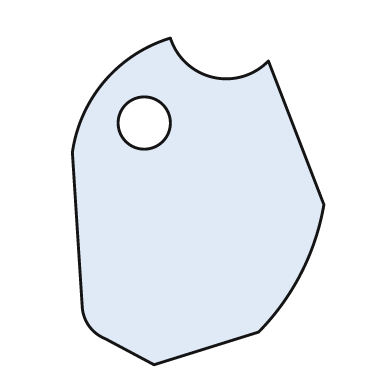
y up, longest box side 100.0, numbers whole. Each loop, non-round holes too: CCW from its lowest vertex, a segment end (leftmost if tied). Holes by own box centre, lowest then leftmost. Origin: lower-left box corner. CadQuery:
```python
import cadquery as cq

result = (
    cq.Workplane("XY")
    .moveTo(25.0, 0.0)
    .lineTo(57.0, 10.0)
    .threePointArc((70.0, 28.0), (77.0, 49.0))
    .lineTo(60.0, 93.0)
    .threePointArc((43.0, 88.0), (30.0, 100.0))
    .threePointArc((10.0, 87.0), (0.0, 65.0))
    .lineTo(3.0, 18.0)
    .threePointArc((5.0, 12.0), (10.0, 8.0))
    .close()
    .moveTo(22.0, 74.0)
    .circle(8.0)
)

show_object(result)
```